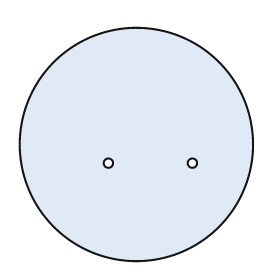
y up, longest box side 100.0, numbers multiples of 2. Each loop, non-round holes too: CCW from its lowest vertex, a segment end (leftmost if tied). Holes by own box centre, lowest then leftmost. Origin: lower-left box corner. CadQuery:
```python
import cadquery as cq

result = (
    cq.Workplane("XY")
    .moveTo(50.0, 50.0)
    .circle(50.0)
    .moveTo(38.0, 42.0)
    .circle(2.0)
    .moveTo(74.0, 42.0)
    .circle(2.0)
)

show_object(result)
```